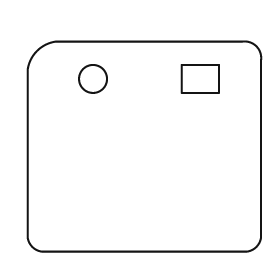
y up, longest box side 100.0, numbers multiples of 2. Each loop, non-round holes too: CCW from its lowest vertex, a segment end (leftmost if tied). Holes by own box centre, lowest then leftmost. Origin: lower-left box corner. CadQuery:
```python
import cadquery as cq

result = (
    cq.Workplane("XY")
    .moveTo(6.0, 0.0)
    .lineTo(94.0, 0.0)
    .threePointArc((98.0, 2.0), (100.0, 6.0))
    .lineTo(100.0, 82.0)
    .threePointArc((98.0, 88.0), (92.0, 90.0))
    .lineTo(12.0, 90.0)
    .threePointArc((4.0, 86.0), (0.0, 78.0))
    .lineTo(0.0, 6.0)
    .threePointArc((2.0, 2.0), (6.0, 0.0))
    .close()
    .moveTo(28.0, 74.0)
    .circle(6.0)
    .moveTo(66.0, 68.0)
    .lineTo(82.0, 68.0)
    .lineTo(82.0, 80.0)
    .lineTo(66.0, 80.0)
    .close()
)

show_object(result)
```